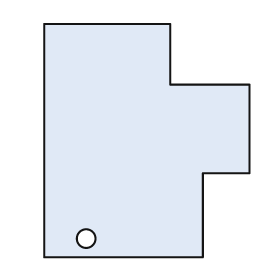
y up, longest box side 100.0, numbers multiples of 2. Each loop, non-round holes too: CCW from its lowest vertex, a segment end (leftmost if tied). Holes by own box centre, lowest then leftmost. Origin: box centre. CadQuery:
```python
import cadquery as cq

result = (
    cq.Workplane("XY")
    .moveTo(-44.0, -50.0)
    .lineTo(24.0, -50.0)
    .lineTo(24.0, -14.0)
    .lineTo(44.0, -14.0)
    .lineTo(44.0, 24.0)
    .lineTo(10.0, 24.0)
    .lineTo(10.0, 50.0)
    .lineTo(-44.0, 50.0)
    .close()
    .moveTo(-26.0, -42.0)
    .circle(4.0)
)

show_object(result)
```